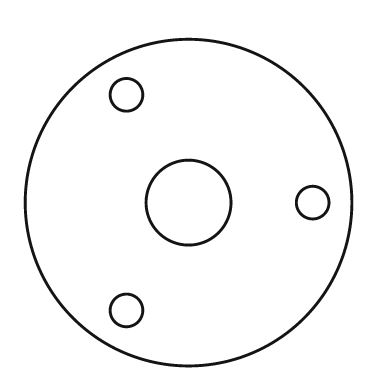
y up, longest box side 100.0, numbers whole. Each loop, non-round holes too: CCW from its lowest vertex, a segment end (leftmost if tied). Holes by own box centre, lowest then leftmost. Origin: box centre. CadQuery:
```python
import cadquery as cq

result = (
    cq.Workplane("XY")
    .moveTo(0.0, 0.0)
    .circle(50.0)
    .moveTo(-19.0, -33.0)
    .circle(5.0)
    .moveTo(0.0, 0.0)
    .circle(13.0)
    .moveTo(38.0, 0.0)
    .circle(5.0)
    .moveTo(-19.0, 33.0)
    .circle(5.0)
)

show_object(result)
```